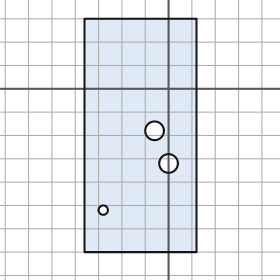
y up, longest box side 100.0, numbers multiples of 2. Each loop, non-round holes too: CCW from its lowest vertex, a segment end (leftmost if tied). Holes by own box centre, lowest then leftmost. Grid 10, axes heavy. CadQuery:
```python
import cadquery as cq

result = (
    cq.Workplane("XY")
    .moveTo(-36.0, -70.0)
    .lineTo(12.0, -70.0)
    .lineTo(12.0, 30.0)
    .lineTo(-36.0, 30.0)
    .close()
    .moveTo(-28.0, -52.0)
    .circle(2.0)
    .moveTo(0.0, -32.0)
    .circle(4.0)
    .moveTo(-6.0, -18.0)
    .circle(4.0)
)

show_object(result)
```